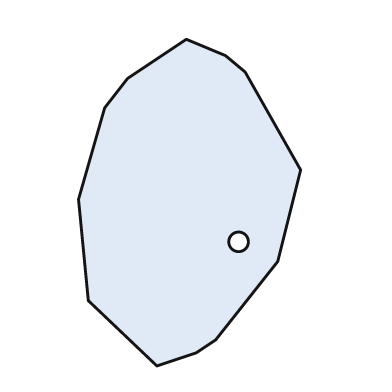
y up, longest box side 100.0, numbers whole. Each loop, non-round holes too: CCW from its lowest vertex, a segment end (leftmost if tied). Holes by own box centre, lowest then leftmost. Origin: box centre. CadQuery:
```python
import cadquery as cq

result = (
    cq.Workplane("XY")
    .moveTo(-10.0, -50.0)
    .lineTo(2.0, -46.0)
    .lineTo(8.0, -42.0)
    .lineTo(27.0, -18.0)
    .lineTo(34.0, 10.0)
    .lineTo(17.0, 40.0)
    .lineTo(11.0, 45.0)
    .lineTo(-1.0, 50.0)
    .lineTo(-19.0, 38.0)
    .lineTo(-26.0, 29.0)
    .lineTo(-34.0, 1.0)
    .lineTo(-31.0, -30.0)
    .close()
    .moveTo(15.0, -12.0)
    .circle(3.0)
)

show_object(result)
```